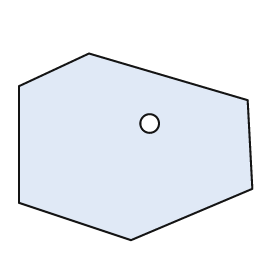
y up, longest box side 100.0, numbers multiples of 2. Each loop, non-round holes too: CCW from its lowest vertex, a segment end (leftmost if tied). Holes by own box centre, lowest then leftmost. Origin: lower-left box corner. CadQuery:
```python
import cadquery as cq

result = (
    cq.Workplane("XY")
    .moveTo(48.0, 0.0)
    .lineTo(100.0, 22.0)
    .lineTo(98.0, 60.0)
    .lineTo(30.0, 80.0)
    .lineTo(0.0, 66.0)
    .lineTo(0.0, 16.0)
    .close()
    .moveTo(56.0, 50.0)
    .circle(4.0)
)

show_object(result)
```